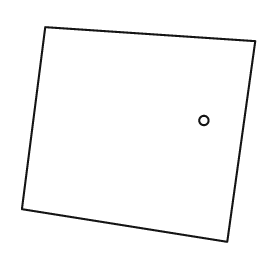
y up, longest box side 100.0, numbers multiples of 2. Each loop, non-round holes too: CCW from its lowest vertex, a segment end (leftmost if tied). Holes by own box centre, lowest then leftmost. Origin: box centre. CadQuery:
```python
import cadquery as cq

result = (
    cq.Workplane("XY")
    .moveTo(38.0, -46.0)
    .lineTo(50.0, 40.0)
    .lineTo(-40.0, 46.0)
    .lineTo(-50.0, -32.0)
    .close()
    .moveTo(28.0, 6.0)
    .circle(2.0)
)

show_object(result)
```